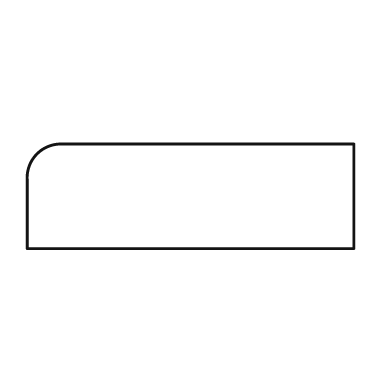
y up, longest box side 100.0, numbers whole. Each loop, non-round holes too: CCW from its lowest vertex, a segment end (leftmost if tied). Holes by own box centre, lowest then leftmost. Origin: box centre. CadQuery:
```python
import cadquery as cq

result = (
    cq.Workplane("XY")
    .moveTo(-50.0, -16.0)
    .lineTo(50.0, -16.0)
    .lineTo(50.0, 16.0)
    .lineTo(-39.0, 16.0)
    .threePointArc((-47.0, 13.0), (-50.0, 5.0))
    .close()
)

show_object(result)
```